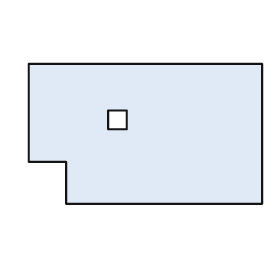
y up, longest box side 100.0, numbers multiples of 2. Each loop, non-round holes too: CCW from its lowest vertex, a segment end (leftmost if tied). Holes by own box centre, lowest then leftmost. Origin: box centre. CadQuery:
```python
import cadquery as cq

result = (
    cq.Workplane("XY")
    .moveTo(-34.0, -30.0)
    .lineTo(50.0, -30.0)
    .lineTo(50.0, 30.0)
    .lineTo(-50.0, 30.0)
    .lineTo(-50.0, -12.0)
    .lineTo(-34.0, -12.0)
    .close()
    .moveTo(-16.0, 2.0)
    .lineTo(-8.0, 2.0)
    .lineTo(-8.0, 10.0)
    .lineTo(-16.0, 10.0)
    .close()
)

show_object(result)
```